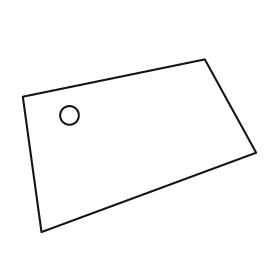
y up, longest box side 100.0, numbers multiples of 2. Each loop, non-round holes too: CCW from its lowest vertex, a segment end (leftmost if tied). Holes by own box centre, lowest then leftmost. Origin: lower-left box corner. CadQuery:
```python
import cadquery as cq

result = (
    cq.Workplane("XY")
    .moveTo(8.0, 0.0)
    .lineTo(100.0, 34.0)
    .lineTo(78.0, 74.0)
    .lineTo(0.0, 58.0)
    .close()
    .moveTo(20.0, 50.0)
    .circle(4.0)
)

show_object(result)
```